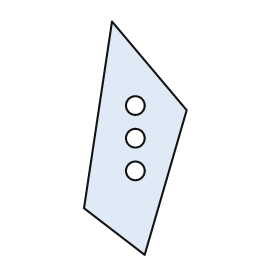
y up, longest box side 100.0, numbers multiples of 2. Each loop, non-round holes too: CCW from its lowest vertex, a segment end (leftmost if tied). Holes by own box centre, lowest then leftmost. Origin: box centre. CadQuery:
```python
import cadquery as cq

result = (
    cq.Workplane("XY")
    .moveTo(4.0, -50.0)
    .lineTo(22.0, 12.0)
    .lineTo(-10.0, 50.0)
    .lineTo(-22.0, -30.0)
    .close()
    .moveTo(0.0, -14.0)
    .circle(4.0)
    .moveTo(0.0, 0.0)
    .circle(4.0)
    .moveTo(0.0, 14.0)
    .circle(4.0)
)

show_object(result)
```